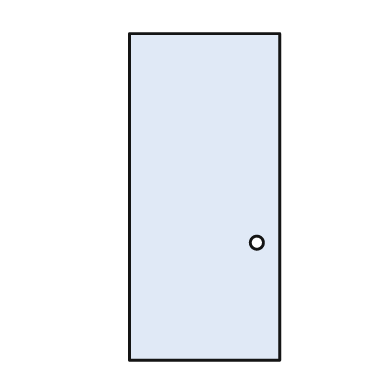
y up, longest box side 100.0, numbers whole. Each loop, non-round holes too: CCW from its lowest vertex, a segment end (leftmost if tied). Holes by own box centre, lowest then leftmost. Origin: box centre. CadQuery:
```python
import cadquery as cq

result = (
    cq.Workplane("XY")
    .moveTo(-23.0, -50.0)
    .lineTo(23.0, -50.0)
    .lineTo(23.0, 50.0)
    .lineTo(-23.0, 50.0)
    .close()
    .moveTo(16.0, -14.0)
    .circle(2.0)
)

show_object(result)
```